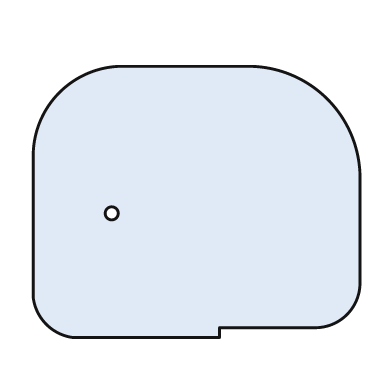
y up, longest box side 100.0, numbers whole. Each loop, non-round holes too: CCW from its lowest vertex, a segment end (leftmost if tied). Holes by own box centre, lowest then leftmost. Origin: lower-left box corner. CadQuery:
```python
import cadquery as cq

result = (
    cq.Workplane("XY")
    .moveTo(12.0, 0.0)
    .lineTo(57.0, 0.0)
    .lineTo(57.0, 3.0)
    .lineTo(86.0, 3.0)
    .threePointArc((96.0, 7.0), (100.0, 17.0))
    .lineTo(100.0, 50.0)
    .threePointArc((90.0, 73.0), (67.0, 83.0))
    .lineTo(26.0, 83.0)
    .threePointArc((8.0, 75.0), (0.0, 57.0))
    .lineTo(0.0, 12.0)
    .threePointArc((4.0, 4.0), (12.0, 0.0))
    .close()
    .moveTo(24.0, 38.0)
    .circle(2.0)
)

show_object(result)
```